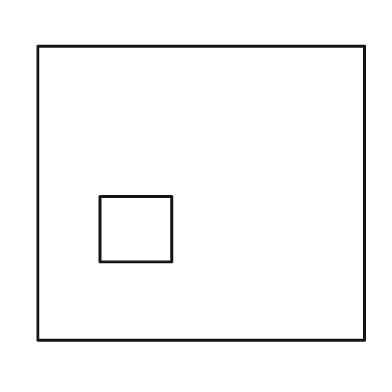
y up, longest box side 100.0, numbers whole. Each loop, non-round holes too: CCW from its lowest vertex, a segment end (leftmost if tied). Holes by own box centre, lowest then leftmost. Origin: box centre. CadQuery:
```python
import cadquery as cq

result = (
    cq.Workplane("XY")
    .moveTo(-50.0, -45.0)
    .lineTo(50.0, -45.0)
    .lineTo(50.0, 45.0)
    .lineTo(-50.0, 45.0)
    .close()
    .moveTo(-31.0, -21.0)
    .lineTo(-9.0, -21.0)
    .lineTo(-9.0, -1.0)
    .lineTo(-31.0, -1.0)
    .close()
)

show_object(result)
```